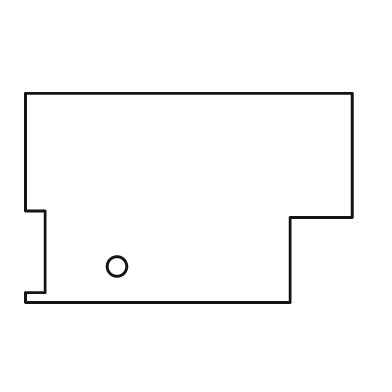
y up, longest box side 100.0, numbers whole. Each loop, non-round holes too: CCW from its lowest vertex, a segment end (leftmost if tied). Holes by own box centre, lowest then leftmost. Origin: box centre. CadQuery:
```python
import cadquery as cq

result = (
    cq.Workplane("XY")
    .moveTo(-50.0, -32.0)
    .lineTo(31.0, -32.0)
    .lineTo(31.0, -6.0)
    .lineTo(50.0, -6.0)
    .lineTo(50.0, 32.0)
    .lineTo(-50.0, 32.0)
    .lineTo(-50.0, -4.0)
    .lineTo(-44.0, -4.0)
    .lineTo(-44.0, -29.0)
    .lineTo(-50.0, -29.0)
    .close()
    .moveTo(-22.0, -21.0)
    .circle(3.0)
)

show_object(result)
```